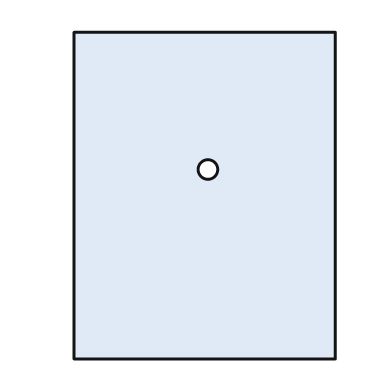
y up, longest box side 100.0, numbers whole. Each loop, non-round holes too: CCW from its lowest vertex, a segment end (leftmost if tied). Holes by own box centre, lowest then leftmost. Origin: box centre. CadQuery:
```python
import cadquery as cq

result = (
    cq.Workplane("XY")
    .moveTo(-40.0, -50.0)
    .lineTo(40.0, -50.0)
    .lineTo(40.0, 50.0)
    .lineTo(-40.0, 50.0)
    .close()
    .moveTo(1.0, 8.0)
    .circle(3.0)
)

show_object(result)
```